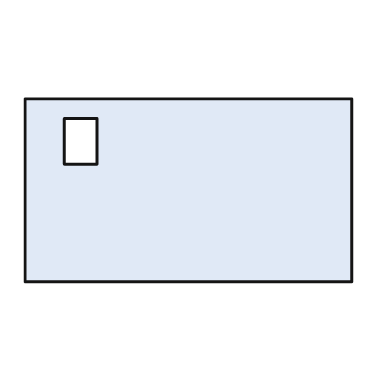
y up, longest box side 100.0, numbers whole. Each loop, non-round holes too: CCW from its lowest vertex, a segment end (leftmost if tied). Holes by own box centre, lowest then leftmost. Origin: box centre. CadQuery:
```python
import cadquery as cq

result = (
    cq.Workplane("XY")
    .moveTo(-50.0, -28.0)
    .lineTo(50.0, -28.0)
    .lineTo(50.0, 28.0)
    .lineTo(-50.0, 28.0)
    .close()
    .moveTo(-38.0, 8.0)
    .lineTo(-28.0, 8.0)
    .lineTo(-28.0, 22.0)
    .lineTo(-38.0, 22.0)
    .close()
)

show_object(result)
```